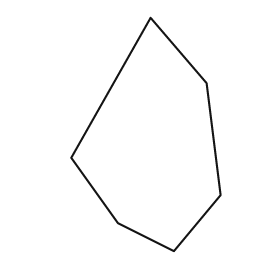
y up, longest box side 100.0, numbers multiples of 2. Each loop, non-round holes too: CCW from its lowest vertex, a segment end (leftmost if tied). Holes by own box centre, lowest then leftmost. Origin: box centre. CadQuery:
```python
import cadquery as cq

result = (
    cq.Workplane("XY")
    .moveTo(12.0, -50.0)
    .lineTo(32.0, -26.0)
    .lineTo(26.0, 22.0)
    .lineTo(2.0, 50.0)
    .lineTo(-32.0, -10.0)
    .lineTo(-12.0, -38.0)
    .close()
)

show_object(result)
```